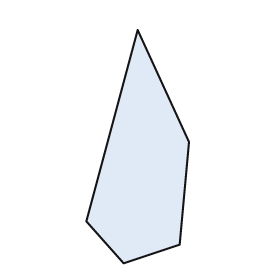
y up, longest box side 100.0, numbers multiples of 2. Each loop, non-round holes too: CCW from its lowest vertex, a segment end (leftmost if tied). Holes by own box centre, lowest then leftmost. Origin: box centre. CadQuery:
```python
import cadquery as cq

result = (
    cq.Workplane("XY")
    .moveTo(-6.0, -50.0)
    .lineTo(18.0, -42.0)
    .lineTo(22.0, 2.0)
    .lineTo(0.0, 50.0)
    .lineTo(-22.0, -32.0)
    .close()
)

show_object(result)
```